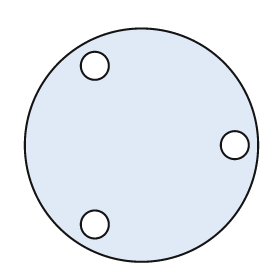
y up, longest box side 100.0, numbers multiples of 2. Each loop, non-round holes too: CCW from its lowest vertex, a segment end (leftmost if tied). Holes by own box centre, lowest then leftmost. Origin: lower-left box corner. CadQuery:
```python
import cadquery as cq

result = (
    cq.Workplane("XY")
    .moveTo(50.0, 50.0)
    .circle(50.0)
    .moveTo(30.0, 16.0)
    .circle(6.0)
    .moveTo(90.0, 50.0)
    .circle(6.0)
    .moveTo(30.0, 84.0)
    .circle(6.0)
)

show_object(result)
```